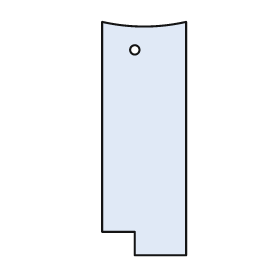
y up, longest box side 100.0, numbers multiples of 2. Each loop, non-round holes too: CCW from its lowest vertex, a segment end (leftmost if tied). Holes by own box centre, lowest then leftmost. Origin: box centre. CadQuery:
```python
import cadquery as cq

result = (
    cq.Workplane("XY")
    .moveTo(-4.0, -50.0)
    .lineTo(18.0, -50.0)
    .lineTo(18.0, 50.0)
    .threePointArc((0.0, 48.0), (-18.0, 50.0))
    .lineTo(-18.0, -40.0)
    .lineTo(-4.0, -40.0)
    .close()
    .moveTo(-4.0, 38.0)
    .circle(2.0)
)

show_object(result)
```